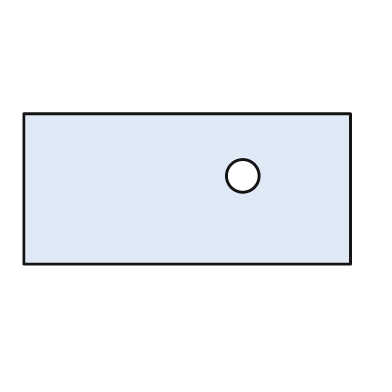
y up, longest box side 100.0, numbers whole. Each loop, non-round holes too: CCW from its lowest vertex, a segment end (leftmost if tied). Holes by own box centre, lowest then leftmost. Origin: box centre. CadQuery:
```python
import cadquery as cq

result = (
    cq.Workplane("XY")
    .moveTo(-50.0, -23.0)
    .lineTo(50.0, -23.0)
    .lineTo(50.0, 23.0)
    .lineTo(-50.0, 23.0)
    .close()
    .moveTo(17.0, 4.0)
    .circle(5.0)
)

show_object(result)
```